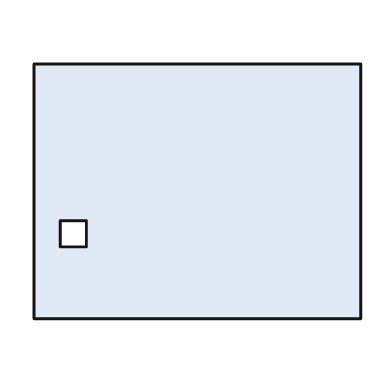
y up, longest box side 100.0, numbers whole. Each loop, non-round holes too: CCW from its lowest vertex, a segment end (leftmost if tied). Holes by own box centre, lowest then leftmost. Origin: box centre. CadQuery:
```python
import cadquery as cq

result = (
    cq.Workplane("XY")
    .moveTo(-50.0, -39.0)
    .lineTo(50.0, -39.0)
    .lineTo(50.0, 39.0)
    .lineTo(-50.0, 39.0)
    .close()
    .moveTo(-42.0, -17.0)
    .lineTo(-34.0, -17.0)
    .lineTo(-34.0, -9.0)
    .lineTo(-42.0, -9.0)
    .close()
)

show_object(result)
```